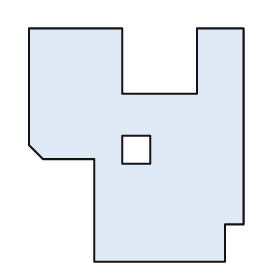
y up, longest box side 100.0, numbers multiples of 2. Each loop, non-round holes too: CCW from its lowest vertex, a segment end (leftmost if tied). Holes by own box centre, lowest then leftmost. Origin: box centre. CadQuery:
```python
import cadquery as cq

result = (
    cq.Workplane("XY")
    .moveTo(-18.0, -50.0)
    .lineTo(38.0, -50.0)
    .lineTo(38.0, -34.0)
    .lineTo(46.0, -34.0)
    .lineTo(46.0, 50.0)
    .lineTo(26.0, 50.0)
    .lineTo(26.0, 22.0)
    .lineTo(-6.0, 22.0)
    .lineTo(-6.0, 50.0)
    .lineTo(-46.0, 50.0)
    .lineTo(-46.0, 0.0)
    .lineTo(-40.0, -6.0)
    .lineTo(-18.0, -6.0)
    .close()
    .moveTo(-6.0, -8.0)
    .lineTo(6.0, -8.0)
    .lineTo(6.0, 4.0)
    .lineTo(-6.0, 4.0)
    .close()
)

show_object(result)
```